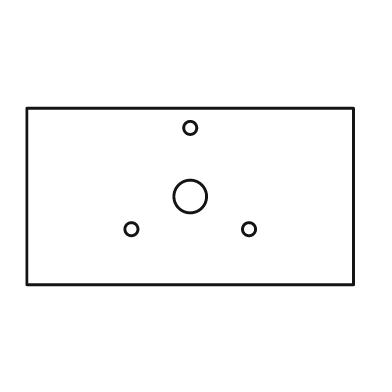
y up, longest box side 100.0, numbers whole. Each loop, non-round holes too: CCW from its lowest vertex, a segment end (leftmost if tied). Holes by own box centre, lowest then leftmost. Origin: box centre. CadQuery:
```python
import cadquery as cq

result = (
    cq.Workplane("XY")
    .moveTo(-50.0, -27.0)
    .lineTo(50.0, -27.0)
    .lineTo(50.0, 27.0)
    .lineTo(-50.0, 27.0)
    .close()
    .moveTo(-18.0, -10.0)
    .circle(2.0)
    .moveTo(18.0, -10.0)
    .circle(2.0)
    .moveTo(0.0, 0.0)
    .circle(5.0)
    .moveTo(0.0, 21.0)
    .circle(2.0)
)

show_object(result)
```